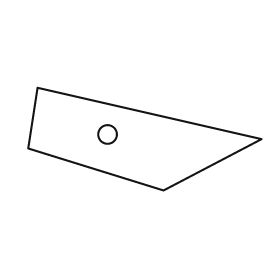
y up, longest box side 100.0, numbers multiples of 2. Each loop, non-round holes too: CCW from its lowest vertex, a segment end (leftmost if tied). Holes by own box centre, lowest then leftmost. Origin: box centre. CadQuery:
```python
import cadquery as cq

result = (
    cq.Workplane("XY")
    .moveTo(8.0, -22.0)
    .lineTo(50.0, 0.0)
    .lineTo(-46.0, 22.0)
    .lineTo(-50.0, -4.0)
    .close()
    .moveTo(-16.0, 2.0)
    .circle(4.0)
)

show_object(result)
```